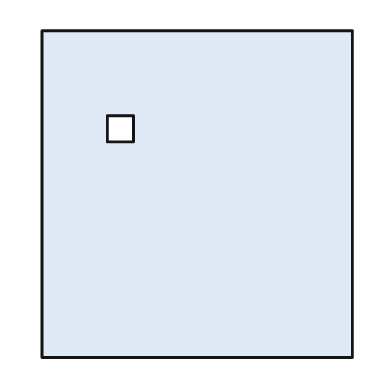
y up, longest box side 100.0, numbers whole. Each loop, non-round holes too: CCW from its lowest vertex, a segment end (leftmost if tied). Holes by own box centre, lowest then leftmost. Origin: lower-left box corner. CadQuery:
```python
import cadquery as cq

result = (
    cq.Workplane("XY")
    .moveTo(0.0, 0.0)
    .lineTo(95.0, 0.0)
    .lineTo(95.0, 100.0)
    .lineTo(0.0, 100.0)
    .close()
    .moveTo(20.0, 66.0)
    .lineTo(28.0, 66.0)
    .lineTo(28.0, 74.0)
    .lineTo(20.0, 74.0)
    .close()
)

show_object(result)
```